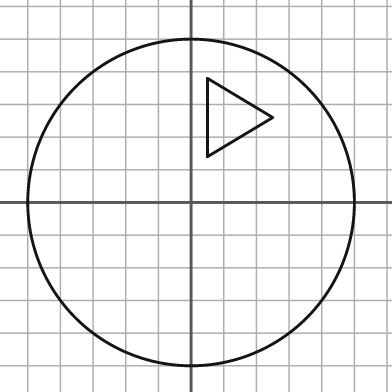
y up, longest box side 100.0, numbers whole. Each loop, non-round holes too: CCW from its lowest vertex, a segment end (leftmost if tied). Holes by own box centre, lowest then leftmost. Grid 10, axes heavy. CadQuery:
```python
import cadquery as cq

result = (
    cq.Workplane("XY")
    .moveTo(0.0, 0.0)
    .circle(50.0)
    .moveTo(5.0, 14.0)
    .lineTo(25.0, 26.0)
    .lineTo(5.0, 38.0)
    .close()
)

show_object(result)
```